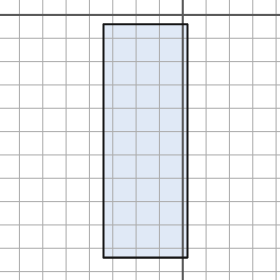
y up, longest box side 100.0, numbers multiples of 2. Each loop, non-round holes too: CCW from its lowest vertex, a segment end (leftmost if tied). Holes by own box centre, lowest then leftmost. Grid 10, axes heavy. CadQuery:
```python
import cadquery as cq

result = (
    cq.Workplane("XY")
    .moveTo(-34.0, -104.0)
    .lineTo(2.0, -104.0)
    .lineTo(2.0, -4.0)
    .lineTo(-34.0, -4.0)
    .close()
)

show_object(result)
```